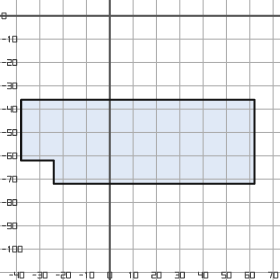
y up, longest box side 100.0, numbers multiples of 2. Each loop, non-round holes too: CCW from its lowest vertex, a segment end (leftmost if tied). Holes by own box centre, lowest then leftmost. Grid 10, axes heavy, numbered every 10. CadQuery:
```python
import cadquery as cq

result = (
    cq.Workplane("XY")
    .moveTo(-24.0, -72.0)
    .lineTo(62.0, -72.0)
    .lineTo(62.0, -36.0)
    .lineTo(-38.0, -36.0)
    .lineTo(-38.0, -62.0)
    .lineTo(-24.0, -62.0)
    .close()
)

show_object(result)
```